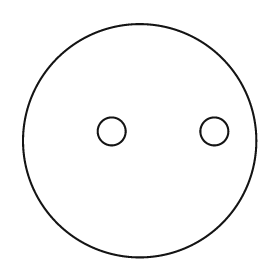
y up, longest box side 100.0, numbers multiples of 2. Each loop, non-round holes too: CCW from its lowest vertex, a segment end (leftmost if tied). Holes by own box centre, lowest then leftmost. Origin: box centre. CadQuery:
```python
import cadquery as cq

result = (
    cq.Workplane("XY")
    .moveTo(0.0, 0.0)
    .circle(50.0)
    .moveTo(-12.0, 4.0)
    .circle(6.0)
    .moveTo(32.0, 4.0)
    .circle(6.0)
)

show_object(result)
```